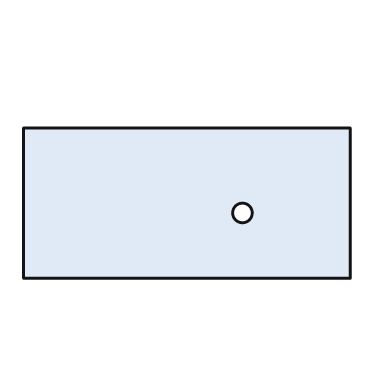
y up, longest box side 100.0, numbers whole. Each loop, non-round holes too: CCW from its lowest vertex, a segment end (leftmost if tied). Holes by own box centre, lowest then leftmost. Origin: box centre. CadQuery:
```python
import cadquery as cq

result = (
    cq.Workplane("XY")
    .moveTo(-50.0, -23.0)
    .lineTo(50.0, -23.0)
    .lineTo(50.0, 23.0)
    .lineTo(-50.0, 23.0)
    .close()
    .moveTo(17.0, -3.0)
    .circle(3.0)
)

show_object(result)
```